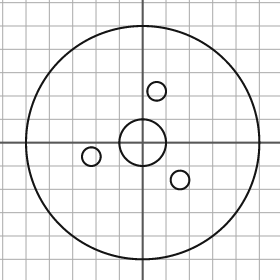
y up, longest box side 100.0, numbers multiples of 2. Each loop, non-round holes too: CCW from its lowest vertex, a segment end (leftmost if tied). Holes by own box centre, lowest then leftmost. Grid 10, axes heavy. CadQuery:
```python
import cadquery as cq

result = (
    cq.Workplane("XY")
    .moveTo(0.0, 0.0)
    .circle(50.0)
    .moveTo(16.0, -16.0)
    .circle(4.0)
    .moveTo(-22.0, -6.0)
    .circle(4.0)
    .moveTo(0.0, 0.0)
    .circle(10.0)
    .moveTo(6.0, 22.0)
    .circle(4.0)
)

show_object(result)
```